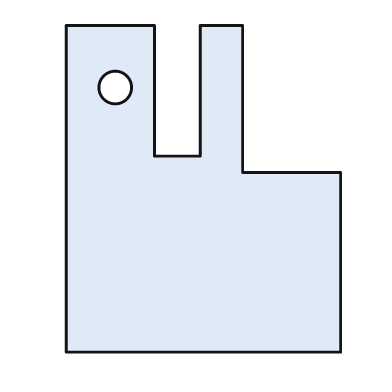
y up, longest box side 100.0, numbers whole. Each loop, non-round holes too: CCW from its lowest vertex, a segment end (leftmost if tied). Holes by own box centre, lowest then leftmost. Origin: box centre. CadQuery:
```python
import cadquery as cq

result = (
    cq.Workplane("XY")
    .moveTo(-42.0, -50.0)
    .lineTo(42.0, -50.0)
    .lineTo(42.0, 5.0)
    .lineTo(12.0, 5.0)
    .lineTo(12.0, 50.0)
    .lineTo(-1.0, 50.0)
    .lineTo(-1.0, 10.0)
    .lineTo(-15.0, 10.0)
    .lineTo(-15.0, 50.0)
    .lineTo(-42.0, 50.0)
    .close()
    .moveTo(-27.0, 31.0)
    .circle(5.0)
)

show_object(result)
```